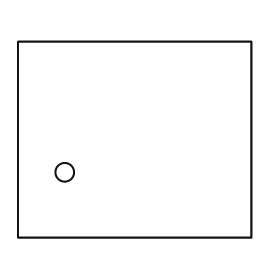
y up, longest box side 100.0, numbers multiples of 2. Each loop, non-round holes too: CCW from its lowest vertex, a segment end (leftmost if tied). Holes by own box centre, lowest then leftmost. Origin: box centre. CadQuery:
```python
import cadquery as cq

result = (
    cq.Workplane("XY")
    .moveTo(-50.0, -42.0)
    .lineTo(50.0, -42.0)
    .lineTo(50.0, 42.0)
    .lineTo(-50.0, 42.0)
    .close()
    .moveTo(-30.0, -14.0)
    .circle(4.0)
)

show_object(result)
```